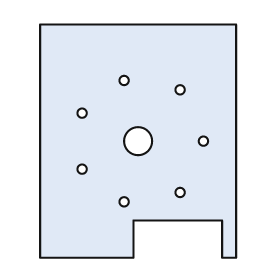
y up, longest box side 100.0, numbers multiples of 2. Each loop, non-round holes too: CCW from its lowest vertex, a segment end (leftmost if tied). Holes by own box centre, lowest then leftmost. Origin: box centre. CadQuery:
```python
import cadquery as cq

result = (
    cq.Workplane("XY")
    .moveTo(-42.0, -50.0)
    .lineTo(-2.0, -50.0)
    .lineTo(-2.0, -34.0)
    .lineTo(36.0, -34.0)
    .lineTo(36.0, -50.0)
    .lineTo(42.0, -50.0)
    .lineTo(42.0, 50.0)
    .lineTo(-42.0, 50.0)
    .close()
    .moveTo(-6.0, -26.0)
    .circle(2.0)
    .moveTo(18.0, -22.0)
    .circle(2.0)
    .moveTo(-24.0, -12.0)
    .circle(2.0)
    .moveTo(0.0, 0.0)
    .circle(6.0)
    .moveTo(28.0, 0.0)
    .circle(2.0)
    .moveTo(-24.0, 12.0)
    .circle(2.0)
    .moveTo(18.0, 22.0)
    .circle(2.0)
    .moveTo(-6.0, 26.0)
    .circle(2.0)
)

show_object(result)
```